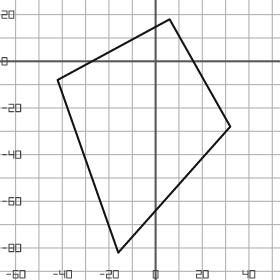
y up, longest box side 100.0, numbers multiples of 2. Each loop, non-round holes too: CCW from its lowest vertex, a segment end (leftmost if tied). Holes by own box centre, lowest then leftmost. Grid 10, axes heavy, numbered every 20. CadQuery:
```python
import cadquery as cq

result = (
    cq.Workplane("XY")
    .moveTo(-16.0, -82.0)
    .lineTo(32.0, -28.0)
    .lineTo(6.0, 18.0)
    .lineTo(-42.0, -8.0)
    .close()
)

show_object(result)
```